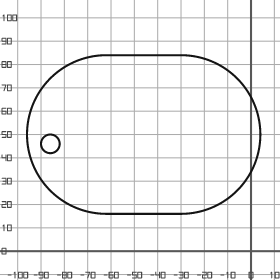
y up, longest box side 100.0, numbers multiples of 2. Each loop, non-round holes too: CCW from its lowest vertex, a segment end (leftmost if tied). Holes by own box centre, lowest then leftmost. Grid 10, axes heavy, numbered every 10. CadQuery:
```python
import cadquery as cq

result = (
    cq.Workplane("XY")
    .moveTo(-62.0, 16.0)
    .lineTo(-30.0, 16.0)
    .threePointArc((4.0, 50.0), (-30.0, 84.0))
    .lineTo(-62.0, 84.0)
    .threePointArc((-96.0, 50.0), (-62.0, 16.0))
    .close()
    .moveTo(-86.0, 46.0)
    .circle(4.0)
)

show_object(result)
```